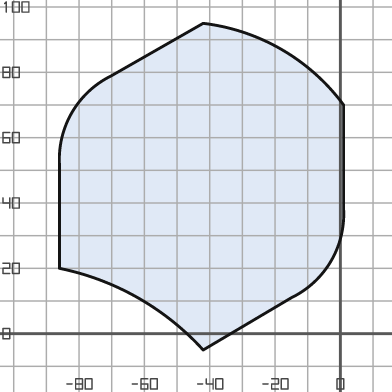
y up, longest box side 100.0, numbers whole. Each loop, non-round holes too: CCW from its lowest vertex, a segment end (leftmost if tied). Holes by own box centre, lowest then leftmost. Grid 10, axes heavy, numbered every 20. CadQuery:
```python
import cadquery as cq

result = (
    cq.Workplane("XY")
    .moveTo(-42.0, -5.0)
    .lineTo(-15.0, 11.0)
    .threePointArc((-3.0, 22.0), (1.0, 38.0))
    .lineTo(1.0, 70.0)
    .threePointArc((-18.0, 87.0), (-42.0, 95.0))
    .lineTo(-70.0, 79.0)
    .threePointArc((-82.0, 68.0), (-86.0, 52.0))
    .lineTo(-86.0, 20.0)
    .threePointArc((-62.0, 11.0), (-42.0, -5.0))
    .close()
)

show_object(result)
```